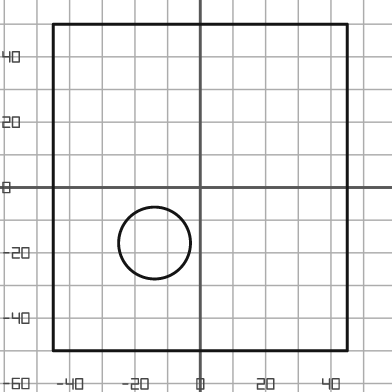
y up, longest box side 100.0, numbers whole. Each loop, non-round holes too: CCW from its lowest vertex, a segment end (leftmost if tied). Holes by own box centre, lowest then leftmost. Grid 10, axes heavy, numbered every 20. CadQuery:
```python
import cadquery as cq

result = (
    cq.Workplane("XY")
    .moveTo(-45.0, -50.0)
    .lineTo(45.0, -50.0)
    .lineTo(45.0, 50.0)
    .lineTo(-45.0, 50.0)
    .close()
    .moveTo(-14.0, -17.0)
    .circle(11.0)
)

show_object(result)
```